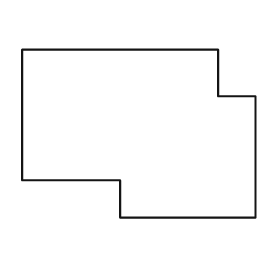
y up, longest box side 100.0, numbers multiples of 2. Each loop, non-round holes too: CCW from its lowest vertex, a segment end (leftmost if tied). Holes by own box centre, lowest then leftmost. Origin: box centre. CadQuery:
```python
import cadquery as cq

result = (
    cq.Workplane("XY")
    .moveTo(-8.0, -36.0)
    .lineTo(50.0, -36.0)
    .lineTo(50.0, 16.0)
    .lineTo(34.0, 16.0)
    .lineTo(34.0, 36.0)
    .lineTo(-50.0, 36.0)
    .lineTo(-50.0, -20.0)
    .lineTo(-8.0, -20.0)
    .close()
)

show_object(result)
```